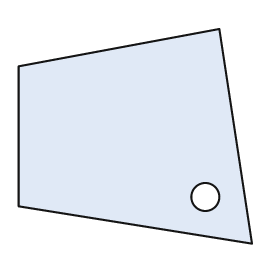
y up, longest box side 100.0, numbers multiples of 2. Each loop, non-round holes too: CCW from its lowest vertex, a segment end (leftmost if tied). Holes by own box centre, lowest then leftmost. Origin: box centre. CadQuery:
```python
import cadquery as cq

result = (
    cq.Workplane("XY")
    .moveTo(50.0, -46.0)
    .lineTo(36.0, 46.0)
    .lineTo(-50.0, 30.0)
    .lineTo(-50.0, -30.0)
    .close()
    .moveTo(30.0, -26.0)
    .circle(6.0)
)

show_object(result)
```